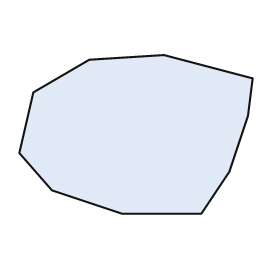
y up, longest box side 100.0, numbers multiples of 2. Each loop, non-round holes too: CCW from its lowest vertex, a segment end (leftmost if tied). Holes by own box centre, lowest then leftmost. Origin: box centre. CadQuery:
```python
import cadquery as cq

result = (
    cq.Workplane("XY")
    .moveTo(-6.0, -34.0)
    .lineTo(28.0, -34.0)
    .lineTo(40.0, -16.0)
    .lineTo(48.0, 8.0)
    .lineTo(50.0, 24.0)
    .lineTo(12.0, 34.0)
    .lineTo(-20.0, 32.0)
    .lineTo(-44.0, 18.0)
    .lineTo(-50.0, -8.0)
    .lineTo(-36.0, -24.0)
    .close()
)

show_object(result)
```